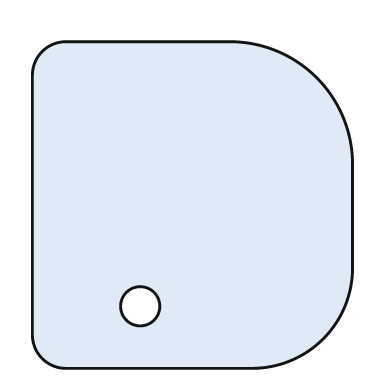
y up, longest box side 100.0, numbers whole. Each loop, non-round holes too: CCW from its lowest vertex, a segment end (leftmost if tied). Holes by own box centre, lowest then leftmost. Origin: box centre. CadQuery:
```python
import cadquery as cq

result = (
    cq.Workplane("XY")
    .moveTo(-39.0, -50.0)
    .lineTo(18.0, -50.0)
    .threePointArc((40.0, -41.0), (49.0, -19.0))
    .lineTo(49.0, 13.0)
    .threePointArc((38.0, 39.0), (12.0, 50.0))
    .lineTo(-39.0, 50.0)
    .threePointArc((-46.0, 47.0), (-49.0, 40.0))
    .lineTo(-49.0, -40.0)
    .threePointArc((-46.0, -47.0), (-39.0, -50.0))
    .close()
    .moveTo(-16.0, -31.0)
    .circle(6.0)
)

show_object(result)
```